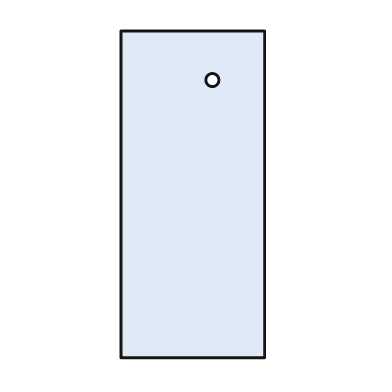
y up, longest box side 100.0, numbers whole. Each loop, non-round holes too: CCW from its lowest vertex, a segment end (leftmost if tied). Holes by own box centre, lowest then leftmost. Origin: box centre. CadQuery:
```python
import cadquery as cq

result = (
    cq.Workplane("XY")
    .moveTo(-22.0, -50.0)
    .lineTo(22.0, -50.0)
    .lineTo(22.0, 50.0)
    .lineTo(-22.0, 50.0)
    .close()
    .moveTo(6.0, 35.0)
    .circle(2.0)
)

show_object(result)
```